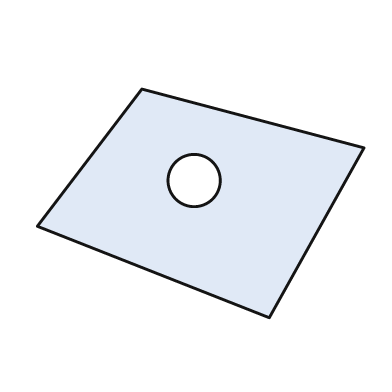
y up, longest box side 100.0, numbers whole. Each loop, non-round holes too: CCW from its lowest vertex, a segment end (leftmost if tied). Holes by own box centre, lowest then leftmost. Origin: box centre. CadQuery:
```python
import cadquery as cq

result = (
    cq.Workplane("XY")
    .moveTo(21.0, -35.0)
    .lineTo(50.0, 17.0)
    .lineTo(-18.0, 35.0)
    .lineTo(-50.0, -7.0)
    .close()
    .moveTo(-2.0, 7.0)
    .circle(8.0)
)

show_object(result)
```